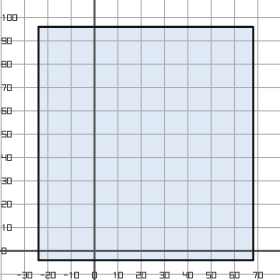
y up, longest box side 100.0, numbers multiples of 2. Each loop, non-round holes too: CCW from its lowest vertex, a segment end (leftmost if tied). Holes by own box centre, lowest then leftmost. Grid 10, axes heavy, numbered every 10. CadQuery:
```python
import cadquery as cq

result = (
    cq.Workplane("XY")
    .moveTo(-24.0, -4.0)
    .lineTo(68.0, -4.0)
    .lineTo(68.0, 96.0)
    .lineTo(-24.0, 96.0)
    .close()
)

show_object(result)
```